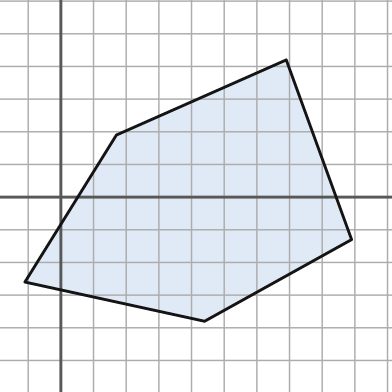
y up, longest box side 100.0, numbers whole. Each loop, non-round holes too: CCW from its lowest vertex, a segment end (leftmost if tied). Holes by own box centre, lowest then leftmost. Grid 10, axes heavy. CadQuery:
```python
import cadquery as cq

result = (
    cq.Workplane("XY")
    .moveTo(44.0, -38.0)
    .lineTo(89.0, -13.0)
    .lineTo(69.0, 42.0)
    .lineTo(17.0, 19.0)
    .lineTo(-11.0, -26.0)
    .close()
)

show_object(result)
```